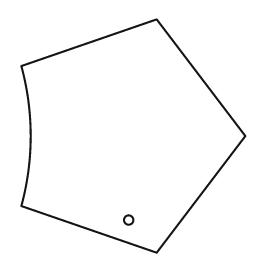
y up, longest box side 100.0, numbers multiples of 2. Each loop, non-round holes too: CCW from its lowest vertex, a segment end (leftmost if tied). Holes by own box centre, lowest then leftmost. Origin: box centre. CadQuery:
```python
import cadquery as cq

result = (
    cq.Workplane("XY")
    .moveTo(10.0, -50.0)
    .lineTo(48.0, 0.0)
    .lineTo(10.0, 50.0)
    .lineTo(-48.0, 30.0)
    .threePointArc((-44.0, 0.0), (-48.0, -30.0))
    .close()
    .moveTo(-2.0, -36.0)
    .circle(2.0)
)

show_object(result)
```